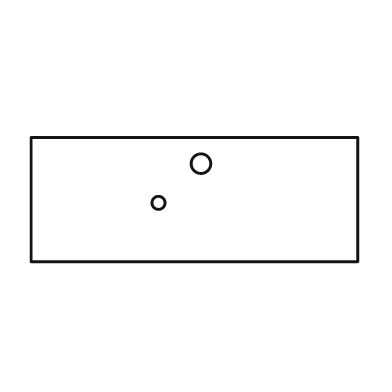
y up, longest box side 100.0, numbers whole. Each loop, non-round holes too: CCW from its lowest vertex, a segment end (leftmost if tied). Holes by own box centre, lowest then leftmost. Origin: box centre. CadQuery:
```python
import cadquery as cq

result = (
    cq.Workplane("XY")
    .moveTo(-50.0, -19.0)
    .lineTo(50.0, -19.0)
    .lineTo(50.0, 19.0)
    .lineTo(-50.0, 19.0)
    .close()
    .moveTo(-11.0, -1.0)
    .circle(2.0)
    .moveTo(2.0, 11.0)
    .circle(3.0)
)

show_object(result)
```